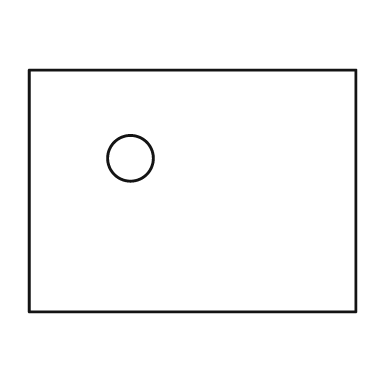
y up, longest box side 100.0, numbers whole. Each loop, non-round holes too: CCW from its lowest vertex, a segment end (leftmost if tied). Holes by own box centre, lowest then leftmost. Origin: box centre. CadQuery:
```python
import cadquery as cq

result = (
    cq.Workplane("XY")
    .moveTo(-50.0, -37.0)
    .lineTo(50.0, -37.0)
    .lineTo(50.0, 37.0)
    .lineTo(-50.0, 37.0)
    .close()
    .moveTo(-19.0, 10.0)
    .circle(7.0)
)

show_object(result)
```